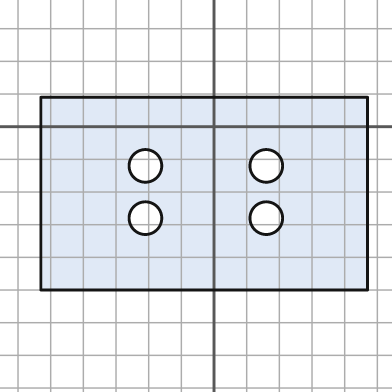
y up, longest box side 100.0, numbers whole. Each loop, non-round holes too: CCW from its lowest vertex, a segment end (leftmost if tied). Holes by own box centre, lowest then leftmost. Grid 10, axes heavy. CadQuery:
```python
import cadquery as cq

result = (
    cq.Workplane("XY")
    .moveTo(-53.0, -50.0)
    .lineTo(47.0, -50.0)
    .lineTo(47.0, 9.0)
    .lineTo(-53.0, 9.0)
    .close()
    .moveTo(-21.0, -28.0)
    .circle(5.0)
    .moveTo(16.0, -28.0)
    .circle(5.0)
    .moveTo(-21.0, -12.0)
    .circle(5.0)
    .moveTo(16.0, -12.0)
    .circle(5.0)
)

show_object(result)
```